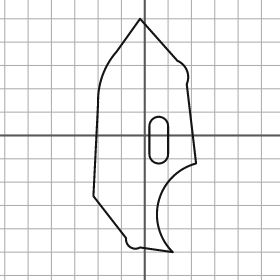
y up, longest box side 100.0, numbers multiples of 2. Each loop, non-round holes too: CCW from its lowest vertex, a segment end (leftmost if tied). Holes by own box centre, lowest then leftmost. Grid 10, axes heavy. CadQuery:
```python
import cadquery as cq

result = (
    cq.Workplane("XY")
    .moveTo(12.0, -50.0)
    .threePointArc((6.0, -28.0), (22.0, -12.0))
    .lineTo(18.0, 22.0)
    .threePointArc((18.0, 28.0), (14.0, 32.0))
    .lineTo(-2.0, 50.0)
    .lineTo(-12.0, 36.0)
    .threePointArc((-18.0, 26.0), (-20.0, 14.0))
    .lineTo(-22.0, -26.0)
    .lineTo(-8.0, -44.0)
    .threePointArc((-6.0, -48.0), (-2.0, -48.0))
    .close()
    .moveTo(2.0, -8.0)
    .threePointArc((6.0, -12.0), (10.0, -8.0))
    .lineTo(10.0, 4.0)
    .threePointArc((6.0, 8.0), (2.0, 4.0))
    .close()
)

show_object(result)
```